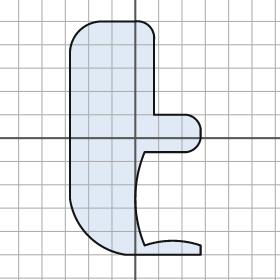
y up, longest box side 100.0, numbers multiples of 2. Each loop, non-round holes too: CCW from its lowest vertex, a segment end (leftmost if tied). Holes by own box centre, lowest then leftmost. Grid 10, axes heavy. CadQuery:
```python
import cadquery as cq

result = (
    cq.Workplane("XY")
    .moveTo(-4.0, -50.0)
    .lineTo(28.0, -50.0)
    .lineTo(28.0, -46.0)
    .threePointArc((16.0, -44.0), (4.0, -46.0))
    .threePointArc((0.0, -26.0), (4.0, -6.0))
    .lineTo(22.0, -6.0)
    .threePointArc((26.0, -4.0), (28.0, 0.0))
    .lineTo(28.0, 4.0)
    .threePointArc((26.0, 8.0), (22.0, 10.0))
    .lineTo(8.0, 10.0)
    .lineTo(8.0, 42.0)
    .threePointArc((6.0, 48.0), (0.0, 50.0))
    .lineTo(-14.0, 50.0)
    .threePointArc((-24.0, 46.0), (-28.0, 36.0))
    .lineTo(-28.0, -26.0)
    .threePointArc((-20.0, -42.0), (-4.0, -50.0))
    .close()
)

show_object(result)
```